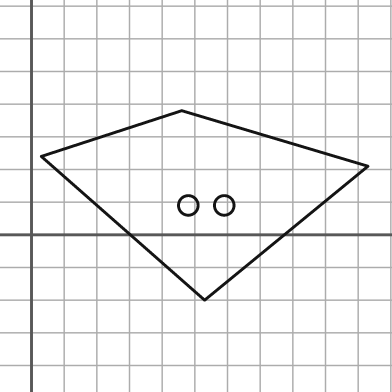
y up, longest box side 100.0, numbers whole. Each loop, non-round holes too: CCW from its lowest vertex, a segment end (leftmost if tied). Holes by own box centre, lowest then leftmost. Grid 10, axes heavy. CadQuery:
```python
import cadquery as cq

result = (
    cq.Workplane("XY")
    .moveTo(53.0, -20.0)
    .lineTo(103.0, 21.0)
    .lineTo(46.0, 38.0)
    .lineTo(3.0, 24.0)
    .close()
    .moveTo(48.0, 9.0)
    .circle(3.0)
    .moveTo(59.0, 9.0)
    .circle(3.0)
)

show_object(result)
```